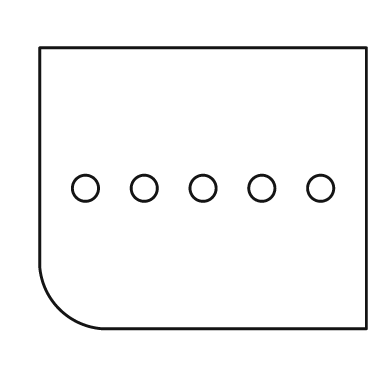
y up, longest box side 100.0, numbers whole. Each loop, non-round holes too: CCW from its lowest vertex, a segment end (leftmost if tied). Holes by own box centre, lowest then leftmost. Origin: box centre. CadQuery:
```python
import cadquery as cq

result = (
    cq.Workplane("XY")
    .moveTo(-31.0, -43.0)
    .lineTo(50.0, -43.0)
    .lineTo(50.0, 43.0)
    .lineTo(-50.0, 43.0)
    .lineTo(-50.0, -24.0)
    .threePointArc((-44.0, -37.0), (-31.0, -43.0))
    .close()
    .moveTo(-36.0, 0.0)
    .circle(4.0)
    .moveTo(-18.0, 0.0)
    .circle(4.0)
    .moveTo(0.0, 0.0)
    .circle(4.0)
    .moveTo(18.0, 0.0)
    .circle(4.0)
    .moveTo(36.0, 0.0)
    .circle(4.0)
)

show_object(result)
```